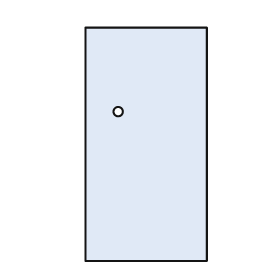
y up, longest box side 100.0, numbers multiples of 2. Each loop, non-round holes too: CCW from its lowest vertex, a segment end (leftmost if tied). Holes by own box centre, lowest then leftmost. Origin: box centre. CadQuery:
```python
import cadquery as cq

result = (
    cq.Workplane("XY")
    .moveTo(-26.0, -50.0)
    .lineTo(26.0, -50.0)
    .lineTo(26.0, 50.0)
    .lineTo(-26.0, 50.0)
    .close()
    .moveTo(-12.0, 14.0)
    .circle(2.0)
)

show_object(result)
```